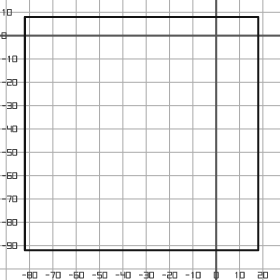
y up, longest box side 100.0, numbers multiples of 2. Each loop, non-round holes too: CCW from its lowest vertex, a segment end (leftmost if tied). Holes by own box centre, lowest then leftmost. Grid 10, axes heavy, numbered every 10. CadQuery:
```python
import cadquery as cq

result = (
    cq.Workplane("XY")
    .moveTo(-82.0, -92.0)
    .lineTo(18.0, -92.0)
    .lineTo(18.0, 8.0)
    .lineTo(-82.0, 8.0)
    .close()
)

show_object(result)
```